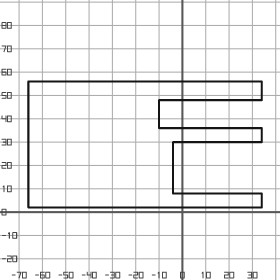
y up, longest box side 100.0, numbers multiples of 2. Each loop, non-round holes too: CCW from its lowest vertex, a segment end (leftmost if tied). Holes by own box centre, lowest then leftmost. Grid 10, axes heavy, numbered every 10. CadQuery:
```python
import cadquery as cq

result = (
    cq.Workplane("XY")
    .moveTo(-66.0, 2.0)
    .lineTo(34.0, 2.0)
    .lineTo(34.0, 8.0)
    .lineTo(-4.0, 8.0)
    .lineTo(-4.0, 30.0)
    .lineTo(34.0, 30.0)
    .lineTo(34.0, 36.0)
    .lineTo(-10.0, 36.0)
    .lineTo(-10.0, 48.0)
    .lineTo(34.0, 48.0)
    .lineTo(34.0, 56.0)
    .lineTo(-66.0, 56.0)
    .close()
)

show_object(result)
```